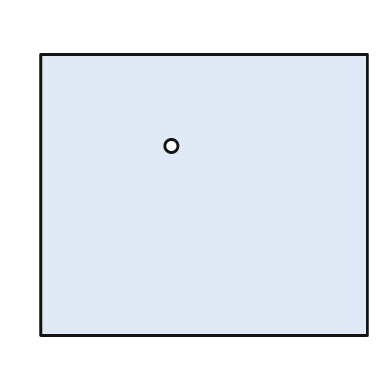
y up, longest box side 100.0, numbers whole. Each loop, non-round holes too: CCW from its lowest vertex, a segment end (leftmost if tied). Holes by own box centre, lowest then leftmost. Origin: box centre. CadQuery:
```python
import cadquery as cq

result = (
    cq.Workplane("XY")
    .moveTo(-50.0, -43.0)
    .lineTo(50.0, -43.0)
    .lineTo(50.0, 43.0)
    .lineTo(-50.0, 43.0)
    .close()
    .moveTo(-10.0, 15.0)
    .circle(2.0)
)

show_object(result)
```